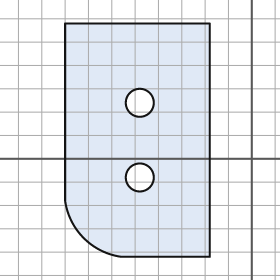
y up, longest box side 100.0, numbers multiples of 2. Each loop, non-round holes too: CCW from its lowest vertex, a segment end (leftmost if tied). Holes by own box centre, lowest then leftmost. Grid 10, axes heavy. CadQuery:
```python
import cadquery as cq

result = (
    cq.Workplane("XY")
    .moveTo(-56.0, -42.0)
    .lineTo(-18.0, -42.0)
    .lineTo(-18.0, 58.0)
    .lineTo(-80.0, 58.0)
    .lineTo(-80.0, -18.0)
    .threePointArc((-72.0, -34.0), (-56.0, -42.0))
    .close()
    .moveTo(-48.0, -8.0)
    .circle(6.0)
    .moveTo(-48.0, 24.0)
    .circle(6.0)
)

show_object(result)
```